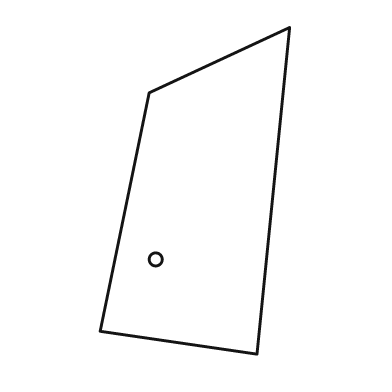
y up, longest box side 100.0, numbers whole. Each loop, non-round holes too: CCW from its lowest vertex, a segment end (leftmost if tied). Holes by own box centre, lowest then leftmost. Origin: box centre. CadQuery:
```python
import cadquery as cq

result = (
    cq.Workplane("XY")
    .moveTo(19.0, -50.0)
    .lineTo(29.0, 50.0)
    .lineTo(-14.0, 30.0)
    .lineTo(-29.0, -43.0)
    .close()
    .moveTo(-12.0, -21.0)
    .circle(2.0)
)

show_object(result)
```